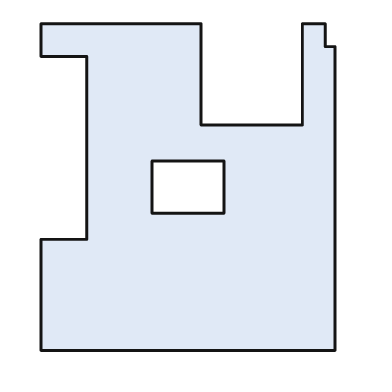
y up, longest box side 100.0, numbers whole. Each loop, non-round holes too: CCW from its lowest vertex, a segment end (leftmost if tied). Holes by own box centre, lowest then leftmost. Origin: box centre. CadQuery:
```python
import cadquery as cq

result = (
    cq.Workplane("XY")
    .moveTo(-45.0, -50.0)
    .lineTo(45.0, -50.0)
    .lineTo(45.0, 43.0)
    .lineTo(42.0, 43.0)
    .lineTo(42.0, 50.0)
    .lineTo(35.0, 50.0)
    .lineTo(35.0, 19.0)
    .lineTo(4.0, 19.0)
    .lineTo(4.0, 50.0)
    .lineTo(-45.0, 50.0)
    .lineTo(-45.0, 40.0)
    .lineTo(-31.0, 40.0)
    .lineTo(-31.0, -16.0)
    .lineTo(-45.0, -16.0)
    .close()
    .moveTo(-11.0, -8.0)
    .lineTo(11.0, -8.0)
    .lineTo(11.0, 8.0)
    .lineTo(-11.0, 8.0)
    .close()
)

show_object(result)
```